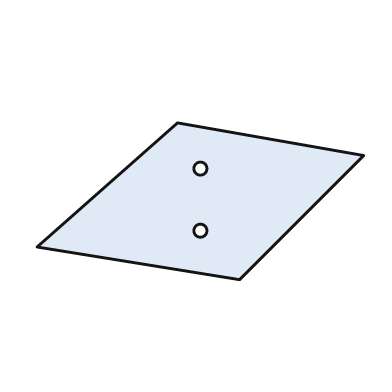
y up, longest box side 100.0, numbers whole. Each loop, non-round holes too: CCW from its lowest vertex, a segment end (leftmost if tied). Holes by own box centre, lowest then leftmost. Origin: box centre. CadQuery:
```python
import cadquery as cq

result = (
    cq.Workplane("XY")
    .moveTo(12.0, -24.0)
    .lineTo(50.0, 14.0)
    .lineTo(-7.0, 24.0)
    .lineTo(-50.0, -14.0)
    .close()
    .moveTo(0.0, -9.0)
    .circle(2.0)
    .moveTo(0.0, 10.0)
    .circle(2.0)
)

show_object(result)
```